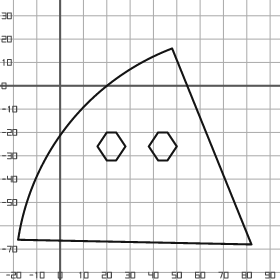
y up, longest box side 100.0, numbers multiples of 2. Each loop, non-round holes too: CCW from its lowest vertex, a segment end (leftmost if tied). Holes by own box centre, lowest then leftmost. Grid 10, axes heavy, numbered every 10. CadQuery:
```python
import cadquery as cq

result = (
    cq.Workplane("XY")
    .moveTo(82.0, -68.0)
    .lineTo(48.0, 16.0)
    .threePointArc((4.0, -16.0), (-18.0, -66.0))
    .close()
    .moveTo(20.0, -32.0)
    .lineTo(24.0, -32.0)
    .lineTo(28.0, -26.0)
    .lineTo(24.0, -20.0)
    .lineTo(20.0, -20.0)
    .lineTo(16.0, -26.0)
    .close()
    .moveTo(42.0, -32.0)
    .lineTo(46.0, -32.0)
    .lineTo(50.0, -26.0)
    .lineTo(46.0, -20.0)
    .lineTo(42.0, -20.0)
    .lineTo(38.0, -26.0)
    .close()
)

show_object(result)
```